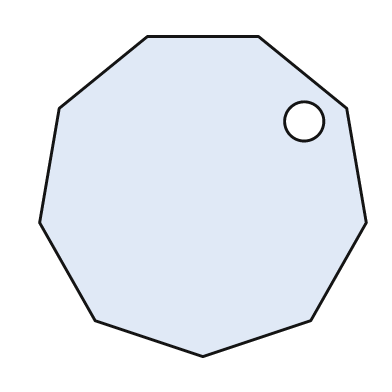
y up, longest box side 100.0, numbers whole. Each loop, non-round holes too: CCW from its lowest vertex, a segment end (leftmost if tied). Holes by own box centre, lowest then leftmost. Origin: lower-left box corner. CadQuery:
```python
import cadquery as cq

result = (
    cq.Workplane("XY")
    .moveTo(50.0, 0.0)
    .lineTo(83.0, 11.0)
    .lineTo(100.0, 41.0)
    .lineTo(94.0, 76.0)
    .lineTo(67.0, 98.0)
    .lineTo(33.0, 98.0)
    .lineTo(6.0, 76.0)
    .lineTo(0.0, 41.0)
    .lineTo(17.0, 11.0)
    .close()
    .moveTo(81.0, 72.0)
    .circle(6.0)
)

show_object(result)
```